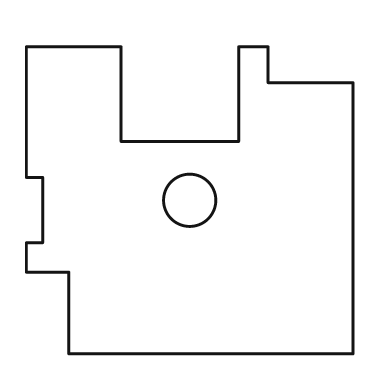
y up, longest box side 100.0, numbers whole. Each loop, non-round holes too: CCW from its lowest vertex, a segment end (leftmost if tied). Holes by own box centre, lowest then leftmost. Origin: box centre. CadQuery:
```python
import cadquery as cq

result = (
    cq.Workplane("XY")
    .moveTo(-37.0, -47.0)
    .lineTo(50.0, -47.0)
    .lineTo(50.0, 36.0)
    .lineTo(24.0, 36.0)
    .lineTo(24.0, 47.0)
    .lineTo(15.0, 47.0)
    .lineTo(15.0, 18.0)
    .lineTo(-21.0, 18.0)
    .lineTo(-21.0, 47.0)
    .lineTo(-50.0, 47.0)
    .lineTo(-50.0, 7.0)
    .lineTo(-45.0, 7.0)
    .lineTo(-45.0, -13.0)
    .lineTo(-50.0, -13.0)
    .lineTo(-50.0, -22.0)
    .lineTo(-37.0, -22.0)
    .close()
    .moveTo(0.0, 0.0)
    .circle(8.0)
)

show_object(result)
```